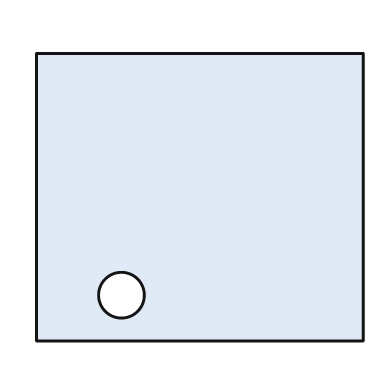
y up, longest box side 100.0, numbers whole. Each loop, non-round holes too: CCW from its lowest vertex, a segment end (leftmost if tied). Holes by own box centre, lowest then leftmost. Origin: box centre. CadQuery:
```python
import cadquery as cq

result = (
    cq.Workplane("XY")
    .moveTo(-50.0, -44.0)
    .lineTo(50.0, -44.0)
    .lineTo(50.0, 44.0)
    .lineTo(-50.0, 44.0)
    .close()
    .moveTo(-24.0, -30.0)
    .circle(7.0)
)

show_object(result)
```